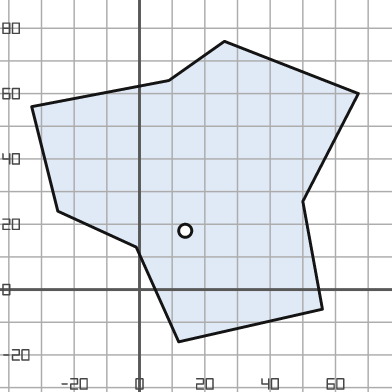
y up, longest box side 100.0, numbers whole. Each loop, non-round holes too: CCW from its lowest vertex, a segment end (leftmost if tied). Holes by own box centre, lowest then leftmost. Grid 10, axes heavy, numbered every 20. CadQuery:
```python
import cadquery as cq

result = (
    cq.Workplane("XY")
    .moveTo(12.0, -16.0)
    .lineTo(56.0, -6.0)
    .lineTo(50.0, 27.0)
    .lineTo(67.0, 60.0)
    .lineTo(26.0, 76.0)
    .lineTo(9.0, 64.0)
    .lineTo(-33.0, 56.0)
    .lineTo(-25.0, 24.0)
    .lineTo(-1.0, 13.0)
    .close()
    .moveTo(14.0, 18.0)
    .circle(2.0)
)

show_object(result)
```